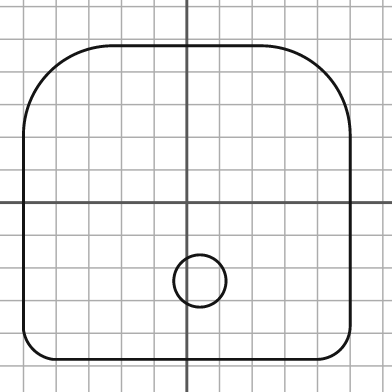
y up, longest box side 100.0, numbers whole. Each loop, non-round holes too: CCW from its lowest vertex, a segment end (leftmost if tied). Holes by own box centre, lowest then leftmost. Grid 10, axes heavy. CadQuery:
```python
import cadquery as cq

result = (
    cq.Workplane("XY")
    .moveTo(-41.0, -48.0)
    .lineTo(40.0, -48.0)
    .threePointArc((47.0, -45.0), (50.0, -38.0))
    .lineTo(50.0, 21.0)
    .threePointArc((42.0, 40.0), (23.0, 48.0))
    .lineTo(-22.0, 48.0)
    .threePointArc((-42.0, 40.0), (-50.0, 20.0))
    .lineTo(-50.0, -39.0)
    .threePointArc((-47.0, -45.0), (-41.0, -48.0))
    .close()
    .moveTo(4.0, -24.0)
    .circle(8.0)
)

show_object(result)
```